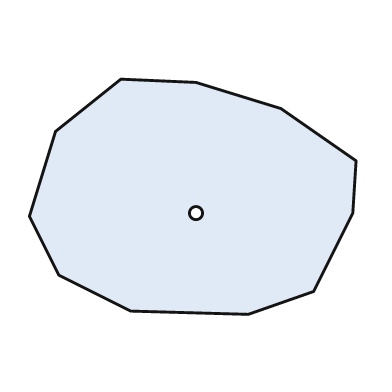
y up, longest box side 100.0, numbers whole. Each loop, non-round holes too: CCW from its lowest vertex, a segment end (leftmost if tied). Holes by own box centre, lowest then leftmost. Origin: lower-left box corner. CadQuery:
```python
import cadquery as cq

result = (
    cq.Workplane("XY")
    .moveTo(67.0, 0.0)
    .lineTo(87.0, 7.0)
    .lineTo(99.0, 31.0)
    .lineTo(100.0, 47.0)
    .lineTo(77.0, 63.0)
    .lineTo(51.0, 71.0)
    .lineTo(28.0, 72.0)
    .lineTo(8.0, 56.0)
    .lineTo(0.0, 30.0)
    .lineTo(9.0, 12.0)
    .lineTo(31.0, 1.0)
    .close()
    .moveTo(51.0, 31.0)
    .circle(2.0)
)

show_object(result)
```